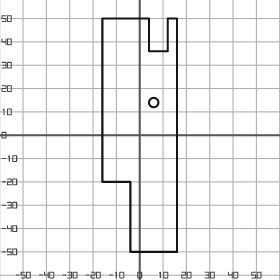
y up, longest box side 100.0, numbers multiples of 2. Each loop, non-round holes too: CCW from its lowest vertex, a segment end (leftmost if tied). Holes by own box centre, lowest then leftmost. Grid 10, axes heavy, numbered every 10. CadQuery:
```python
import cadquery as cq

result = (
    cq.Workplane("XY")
    .moveTo(-4.0, -50.0)
    .lineTo(16.0, -50.0)
    .lineTo(16.0, 50.0)
    .lineTo(12.0, 50.0)
    .lineTo(12.0, 36.0)
    .lineTo(4.0, 36.0)
    .lineTo(4.0, 50.0)
    .lineTo(-16.0, 50.0)
    .lineTo(-16.0, -20.0)
    .lineTo(-4.0, -20.0)
    .close()
    .moveTo(6.0, 14.0)
    .circle(2.0)
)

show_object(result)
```